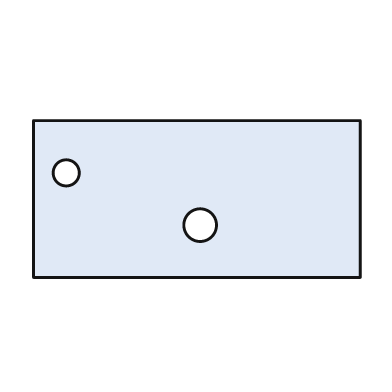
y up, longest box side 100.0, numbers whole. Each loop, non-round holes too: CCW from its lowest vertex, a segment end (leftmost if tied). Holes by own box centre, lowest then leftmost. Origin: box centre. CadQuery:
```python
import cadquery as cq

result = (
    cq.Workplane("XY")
    .moveTo(-50.0, -24.0)
    .lineTo(50.0, -24.0)
    .lineTo(50.0, 24.0)
    .lineTo(-50.0, 24.0)
    .close()
    .moveTo(1.0, -8.0)
    .circle(5.0)
    .moveTo(-40.0, 8.0)
    .circle(4.0)
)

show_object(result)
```